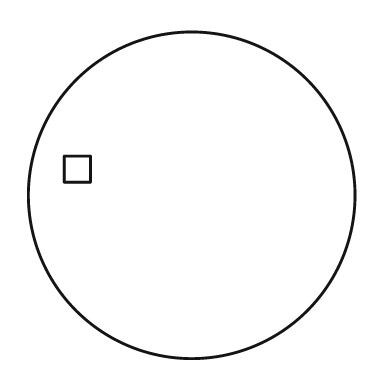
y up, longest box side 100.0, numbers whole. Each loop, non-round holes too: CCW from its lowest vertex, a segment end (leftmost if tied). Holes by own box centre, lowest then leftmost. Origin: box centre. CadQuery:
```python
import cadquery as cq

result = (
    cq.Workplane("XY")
    .moveTo(0.0, 0.0)
    .circle(50.0)
    .moveTo(-39.0, 4.0)
    .lineTo(-31.0, 4.0)
    .lineTo(-31.0, 12.0)
    .lineTo(-39.0, 12.0)
    .close()
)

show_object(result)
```